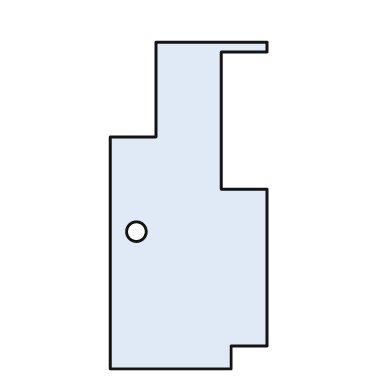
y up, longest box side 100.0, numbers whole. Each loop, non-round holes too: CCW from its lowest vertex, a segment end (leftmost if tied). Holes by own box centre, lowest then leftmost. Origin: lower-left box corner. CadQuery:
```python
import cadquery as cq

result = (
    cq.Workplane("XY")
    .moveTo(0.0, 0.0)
    .lineTo(37.0, 0.0)
    .lineTo(37.0, 7.0)
    .lineTo(48.0, 7.0)
    .lineTo(48.0, 55.0)
    .lineTo(34.0, 55.0)
    .lineTo(34.0, 97.0)
    .lineTo(48.0, 97.0)
    .lineTo(48.0, 100.0)
    .lineTo(14.0, 100.0)
    .lineTo(14.0, 71.0)
    .lineTo(0.0, 71.0)
    .close()
    .moveTo(8.0, 42.0)
    .circle(3.0)
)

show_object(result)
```